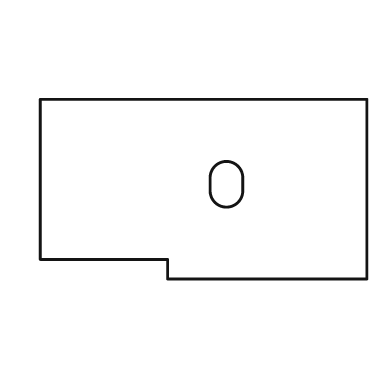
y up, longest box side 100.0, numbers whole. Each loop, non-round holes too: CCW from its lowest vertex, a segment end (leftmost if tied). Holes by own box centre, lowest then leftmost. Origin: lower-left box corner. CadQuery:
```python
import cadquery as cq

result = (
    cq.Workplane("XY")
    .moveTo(39.0, 0.0)
    .lineTo(100.0, 0.0)
    .lineTo(100.0, 55.0)
    .lineTo(0.0, 55.0)
    .lineTo(0.0, 6.0)
    .lineTo(39.0, 6.0)
    .close()
    .moveTo(52.0, 27.0)
    .threePointArc((57.0, 22.0), (62.0, 27.0))
    .lineTo(62.0, 31.0)
    .threePointArc((57.0, 36.0), (52.0, 31.0))
    .close()
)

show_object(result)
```